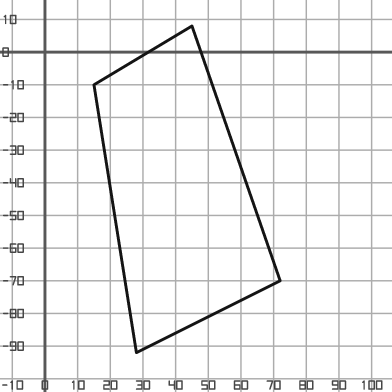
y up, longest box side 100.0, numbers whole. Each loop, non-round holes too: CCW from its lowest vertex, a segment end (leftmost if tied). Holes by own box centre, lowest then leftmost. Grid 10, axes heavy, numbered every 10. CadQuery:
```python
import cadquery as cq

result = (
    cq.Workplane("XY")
    .moveTo(28.0, -92.0)
    .lineTo(72.0, -70.0)
    .lineTo(45.0, 8.0)
    .lineTo(15.0, -10.0)
    .close()
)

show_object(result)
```